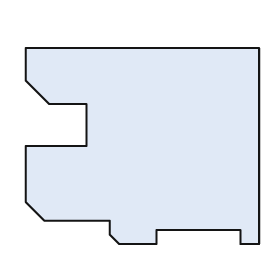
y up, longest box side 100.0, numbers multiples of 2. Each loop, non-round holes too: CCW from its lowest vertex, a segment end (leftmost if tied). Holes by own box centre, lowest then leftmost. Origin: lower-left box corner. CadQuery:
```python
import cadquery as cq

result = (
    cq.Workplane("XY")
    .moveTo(40.0, 0.0)
    .lineTo(56.0, 0.0)
    .lineTo(56.0, 6.0)
    .lineTo(92.0, 6.0)
    .lineTo(92.0, 0.0)
    .lineTo(100.0, 0.0)
    .lineTo(100.0, 84.0)
    .lineTo(0.0, 84.0)
    .lineTo(0.0, 70.0)
    .lineTo(10.0, 60.0)
    .lineTo(26.0, 60.0)
    .lineTo(26.0, 42.0)
    .lineTo(0.0, 42.0)
    .lineTo(0.0, 18.0)
    .lineTo(8.0, 10.0)
    .lineTo(36.0, 10.0)
    .lineTo(36.0, 4.0)
    .close()
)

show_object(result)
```